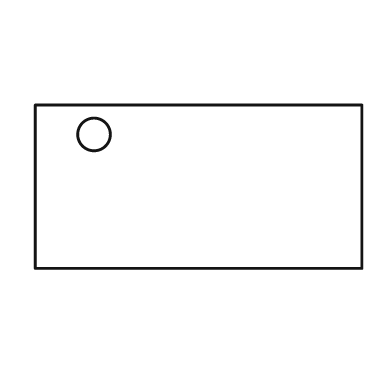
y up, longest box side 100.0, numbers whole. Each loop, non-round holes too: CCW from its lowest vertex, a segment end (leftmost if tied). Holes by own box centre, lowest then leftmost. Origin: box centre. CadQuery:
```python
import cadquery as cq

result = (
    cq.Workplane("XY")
    .moveTo(-50.0, -25.0)
    .lineTo(50.0, -25.0)
    .lineTo(50.0, 25.0)
    .lineTo(-50.0, 25.0)
    .close()
    .moveTo(-32.0, 16.0)
    .circle(5.0)
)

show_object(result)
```